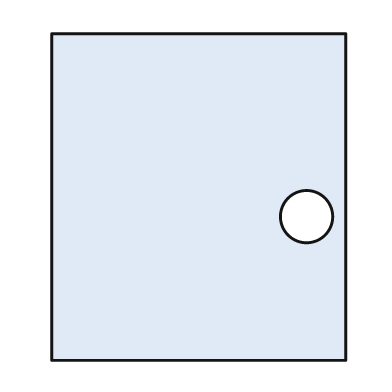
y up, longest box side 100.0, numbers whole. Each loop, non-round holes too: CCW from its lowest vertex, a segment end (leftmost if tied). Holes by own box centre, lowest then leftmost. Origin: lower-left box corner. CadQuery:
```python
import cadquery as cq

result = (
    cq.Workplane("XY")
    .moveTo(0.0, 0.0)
    .lineTo(90.0, 0.0)
    .lineTo(90.0, 100.0)
    .lineTo(0.0, 100.0)
    .close()
    .moveTo(78.0, 44.0)
    .circle(8.0)
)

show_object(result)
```